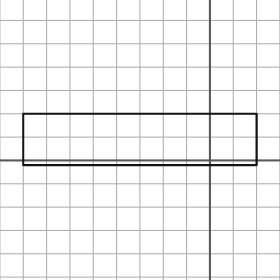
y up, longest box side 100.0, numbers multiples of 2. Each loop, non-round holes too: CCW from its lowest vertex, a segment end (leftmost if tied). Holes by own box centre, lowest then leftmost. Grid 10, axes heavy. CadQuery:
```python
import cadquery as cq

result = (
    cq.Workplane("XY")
    .moveTo(-80.0, -2.0)
    .lineTo(20.0, -2.0)
    .lineTo(20.0, 20.0)
    .lineTo(-80.0, 20.0)
    .close()
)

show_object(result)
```